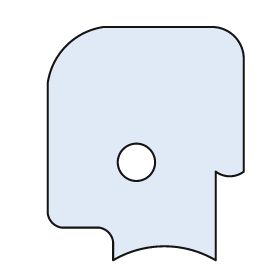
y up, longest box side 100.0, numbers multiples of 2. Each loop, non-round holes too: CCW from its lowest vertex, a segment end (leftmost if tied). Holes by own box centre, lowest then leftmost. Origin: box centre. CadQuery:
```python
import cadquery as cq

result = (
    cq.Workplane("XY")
    .moveTo(-14.0, -50.0)
    .threePointArc((8.0, -44.0), (30.0, -50.0))
    .lineTo(30.0, -12.0)
    .threePointArc((36.0, -14.0), (42.0, -12.0))
    .lineTo(42.0, 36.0)
    .threePointArc((38.0, 46.0), (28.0, 50.0))
    .lineTo(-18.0, 50.0)
    .threePointArc((-34.0, 42.0), (-42.0, 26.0))
    .lineTo(-42.0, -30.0)
    .threePointArc((-40.0, -34.0), (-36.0, -36.0))
    .lineTo(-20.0, -36.0)
    .threePointArc((-16.0, -38.0), (-14.0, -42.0))
    .close()
    .moveTo(-4.0, -8.0)
    .circle(8.0)
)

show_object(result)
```